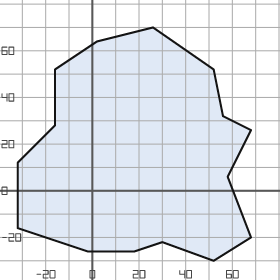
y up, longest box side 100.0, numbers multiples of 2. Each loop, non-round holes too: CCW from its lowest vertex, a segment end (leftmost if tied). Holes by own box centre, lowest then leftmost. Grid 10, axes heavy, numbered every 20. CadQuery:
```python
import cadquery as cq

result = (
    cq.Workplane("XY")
    .moveTo(52.0, -30.0)
    .lineTo(68.0, -20.0)
    .lineTo(58.0, 6.0)
    .lineTo(68.0, 26.0)
    .lineTo(56.0, 32.0)
    .lineTo(52.0, 52.0)
    .lineTo(26.0, 70.0)
    .lineTo(2.0, 64.0)
    .lineTo(-16.0, 52.0)
    .lineTo(-16.0, 28.0)
    .lineTo(-32.0, 12.0)
    .lineTo(-32.0, -16.0)
    .lineTo(-2.0, -26.0)
    .lineTo(18.0, -26.0)
    .lineTo(30.0, -22.0)
    .close()
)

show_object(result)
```